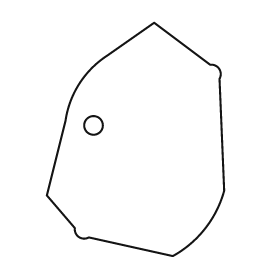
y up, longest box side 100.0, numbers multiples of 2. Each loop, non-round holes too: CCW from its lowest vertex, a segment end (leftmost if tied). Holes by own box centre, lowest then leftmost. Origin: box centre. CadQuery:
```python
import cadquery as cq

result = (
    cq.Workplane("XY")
    .moveTo(16.0, -50.0)
    .threePointArc((30.0, -38.0), (38.0, -22.0))
    .lineTo(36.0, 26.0)
    .threePointArc((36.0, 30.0), (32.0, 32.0))
    .lineTo(8.0, 50.0)
    .lineTo(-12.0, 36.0)
    .threePointArc((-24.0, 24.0), (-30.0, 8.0))
    .lineTo(-38.0, -24.0)
    .lineTo(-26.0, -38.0)
    .threePointArc((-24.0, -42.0), (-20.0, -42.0))
    .close()
    .moveTo(-18.0, 6.0)
    .circle(4.0)
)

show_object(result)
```